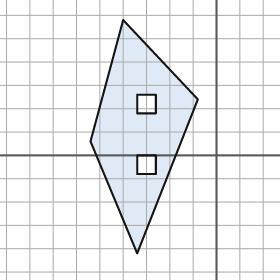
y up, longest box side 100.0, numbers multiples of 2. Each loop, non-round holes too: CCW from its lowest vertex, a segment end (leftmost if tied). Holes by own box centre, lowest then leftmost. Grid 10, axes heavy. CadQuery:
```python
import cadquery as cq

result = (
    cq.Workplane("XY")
    .moveTo(-34.0, -42.0)
    .lineTo(-8.0, 24.0)
    .lineTo(-40.0, 58.0)
    .lineTo(-54.0, 6.0)
    .close()
    .moveTo(-34.0, -8.0)
    .lineTo(-26.0, -8.0)
    .lineTo(-26.0, 0.0)
    .lineTo(-34.0, 0.0)
    .close()
    .moveTo(-34.0, 18.0)
    .lineTo(-26.0, 18.0)
    .lineTo(-26.0, 26.0)
    .lineTo(-34.0, 26.0)
    .close()
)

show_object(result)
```